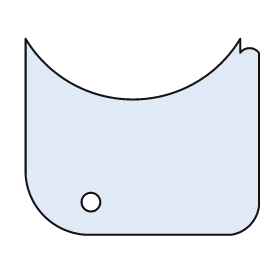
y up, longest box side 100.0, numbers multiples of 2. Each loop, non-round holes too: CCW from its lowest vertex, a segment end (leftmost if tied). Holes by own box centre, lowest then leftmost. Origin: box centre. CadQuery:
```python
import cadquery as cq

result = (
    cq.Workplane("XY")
    .moveTo(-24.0, -42.0)
    .lineTo(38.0, -42.0)
    .threePointArc((46.0, -38.0), (50.0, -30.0))
    .lineTo(50.0, 36.0)
    .threePointArc((46.0, 38.0), (42.0, 36.0))
    .lineTo(42.0, 42.0)
    .threePointArc((-4.0, 16.0), (-50.0, 42.0))
    .lineTo(-50.0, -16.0)
    .threePointArc((-42.0, -34.0), (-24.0, -42.0))
    .close()
    .moveTo(-22.0, -28.0)
    .circle(4.0)
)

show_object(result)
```